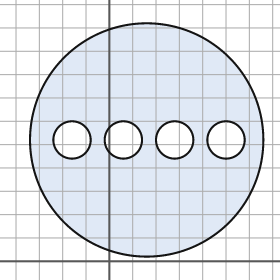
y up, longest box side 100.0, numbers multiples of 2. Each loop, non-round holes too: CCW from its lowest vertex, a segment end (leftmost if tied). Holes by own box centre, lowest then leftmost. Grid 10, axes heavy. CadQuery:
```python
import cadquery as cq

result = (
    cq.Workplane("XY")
    .moveTo(16.0, 52.0)
    .circle(50.0)
    .moveTo(-16.0, 52.0)
    .circle(8.0)
    .moveTo(6.0, 52.0)
    .circle(8.0)
    .moveTo(28.0, 52.0)
    .circle(8.0)
    .moveTo(50.0, 52.0)
    .circle(8.0)
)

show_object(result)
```